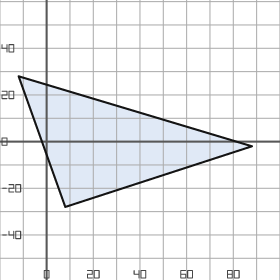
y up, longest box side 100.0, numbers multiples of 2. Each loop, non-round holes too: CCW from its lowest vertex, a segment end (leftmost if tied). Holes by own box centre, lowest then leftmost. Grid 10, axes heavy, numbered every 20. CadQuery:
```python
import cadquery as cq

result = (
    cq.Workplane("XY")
    .moveTo(8.0, -28.0)
    .lineTo(88.0, -2.0)
    .lineTo(-12.0, 28.0)
    .close()
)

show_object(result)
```